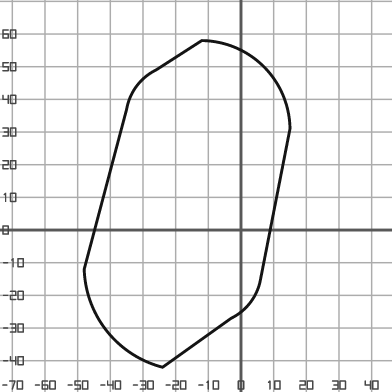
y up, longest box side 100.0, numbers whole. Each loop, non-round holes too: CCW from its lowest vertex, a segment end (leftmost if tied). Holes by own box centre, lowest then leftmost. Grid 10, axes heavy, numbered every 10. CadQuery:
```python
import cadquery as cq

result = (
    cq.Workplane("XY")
    .moveTo(-24.0, -42.0)
    .lineTo(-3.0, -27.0)
    .threePointArc((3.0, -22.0), (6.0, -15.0))
    .lineTo(15.0, 31.0)
    .threePointArc((7.0, 50.0), (-12.0, 58.0))
    .lineTo(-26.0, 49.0)
    .threePointArc((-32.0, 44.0), (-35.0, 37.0))
    .lineTo(-48.0, -12.0)
    .threePointArc((-41.0, -31.0), (-24.0, -42.0))
    .close()
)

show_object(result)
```